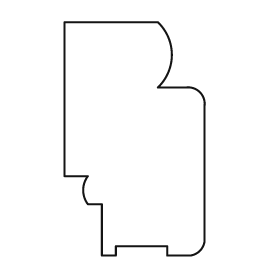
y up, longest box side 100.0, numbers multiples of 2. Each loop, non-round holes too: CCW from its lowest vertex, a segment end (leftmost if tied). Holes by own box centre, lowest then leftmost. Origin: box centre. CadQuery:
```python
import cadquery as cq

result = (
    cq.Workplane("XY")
    .moveTo(-14.0, -50.0)
    .lineTo(-8.0, -50.0)
    .lineTo(-8.0, -46.0)
    .lineTo(14.0, -46.0)
    .lineTo(14.0, -50.0)
    .lineTo(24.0, -50.0)
    .threePointArc((28.0, -48.0), (30.0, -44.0))
    .lineTo(30.0, 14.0)
    .threePointArc((28.0, 20.0), (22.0, 22.0))
    .lineTo(10.0, 22.0)
    .threePointArc((16.0, 36.0), (10.0, 50.0))
    .lineTo(-30.0, 50.0)
    .lineTo(-30.0, -16.0)
    .lineTo(-20.0, -16.0)
    .threePointArc((-22.0, -22.0), (-20.0, -28.0))
    .lineTo(-14.0, -28.0)
    .close()
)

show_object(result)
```